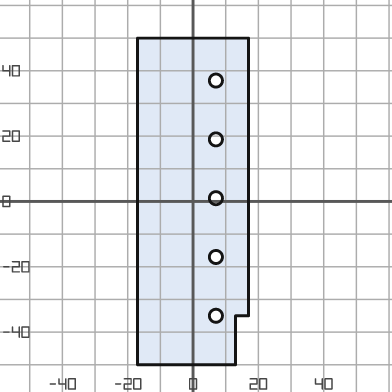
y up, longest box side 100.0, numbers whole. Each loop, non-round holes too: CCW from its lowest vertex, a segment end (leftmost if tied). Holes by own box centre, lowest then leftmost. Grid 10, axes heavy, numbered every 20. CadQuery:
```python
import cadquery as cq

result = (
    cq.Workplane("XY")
    .moveTo(-17.0, -50.0)
    .lineTo(13.0, -50.0)
    .lineTo(13.0, -35.0)
    .lineTo(17.0, -35.0)
    .lineTo(17.0, 50.0)
    .lineTo(-17.0, 50.0)
    .close()
    .moveTo(7.0, -35.0)
    .circle(2.0)
    .moveTo(7.0, -17.0)
    .circle(2.0)
    .moveTo(7.0, 1.0)
    .circle(2.0)
    .moveTo(7.0, 19.0)
    .circle(2.0)
    .moveTo(7.0, 37.0)
    .circle(2.0)
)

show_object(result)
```